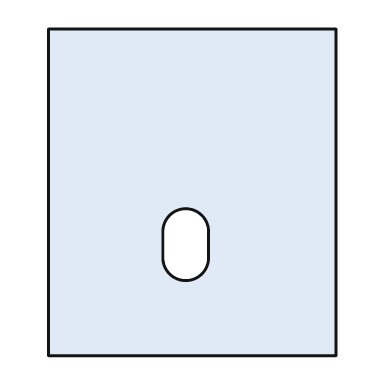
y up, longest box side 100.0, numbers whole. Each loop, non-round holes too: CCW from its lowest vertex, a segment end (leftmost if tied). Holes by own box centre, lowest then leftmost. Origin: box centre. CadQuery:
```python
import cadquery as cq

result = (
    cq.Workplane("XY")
    .moveTo(-44.0, -50.0)
    .lineTo(44.0, -50.0)
    .lineTo(44.0, 50.0)
    .lineTo(-44.0, 50.0)
    .close()
    .moveTo(-9.0, -20.0)
    .threePointArc((-2.0, -27.0), (5.0, -20.0))
    .lineTo(5.0, -12.0)
    .threePointArc((-2.0, -5.0), (-9.0, -12.0))
    .close()
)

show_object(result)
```